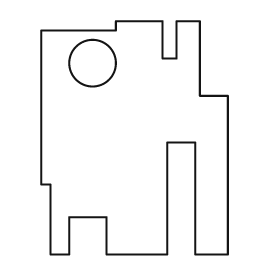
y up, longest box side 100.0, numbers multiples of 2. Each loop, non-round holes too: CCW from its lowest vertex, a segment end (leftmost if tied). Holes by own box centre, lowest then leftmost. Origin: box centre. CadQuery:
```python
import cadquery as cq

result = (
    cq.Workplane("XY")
    .moveTo(-36.0, -50.0)
    .lineTo(-28.0, -50.0)
    .lineTo(-28.0, -34.0)
    .lineTo(-12.0, -34.0)
    .lineTo(-12.0, -50.0)
    .lineTo(14.0, -50.0)
    .lineTo(14.0, -2.0)
    .lineTo(26.0, -2.0)
    .lineTo(26.0, -50.0)
    .lineTo(40.0, -50.0)
    .lineTo(40.0, 18.0)
    .lineTo(28.0, 18.0)
    .lineTo(28.0, 50.0)
    .lineTo(18.0, 50.0)
    .lineTo(18.0, 34.0)
    .lineTo(12.0, 34.0)
    .lineTo(12.0, 50.0)
    .lineTo(-8.0, 50.0)
    .lineTo(-8.0, 46.0)
    .lineTo(-40.0, 46.0)
    .lineTo(-40.0, -20.0)
    .lineTo(-36.0, -20.0)
    .close()
    .moveTo(-18.0, 32.0)
    .circle(10.0)
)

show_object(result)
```